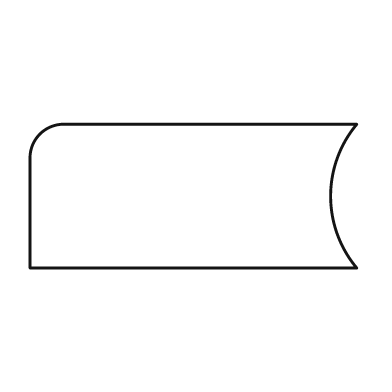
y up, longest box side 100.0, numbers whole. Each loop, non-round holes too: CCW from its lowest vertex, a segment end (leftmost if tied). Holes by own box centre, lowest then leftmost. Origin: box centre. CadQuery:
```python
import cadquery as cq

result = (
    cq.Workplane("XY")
    .moveTo(-50.0, -22.0)
    .lineTo(50.0, -22.0)
    .threePointArc((42.0, 0.0), (50.0, 22.0))
    .lineTo(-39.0, 22.0)
    .threePointArc((-47.0, 19.0), (-50.0, 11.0))
    .close()
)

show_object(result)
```